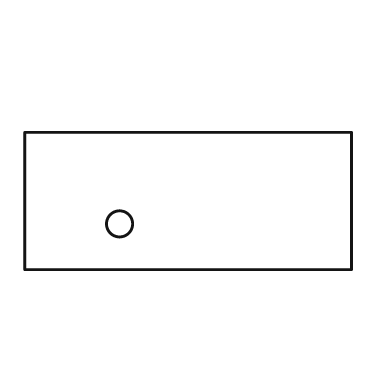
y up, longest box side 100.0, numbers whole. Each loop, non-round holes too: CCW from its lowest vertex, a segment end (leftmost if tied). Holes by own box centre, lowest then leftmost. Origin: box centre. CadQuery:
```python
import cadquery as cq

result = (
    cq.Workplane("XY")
    .moveTo(-50.0, -21.0)
    .lineTo(50.0, -21.0)
    .lineTo(50.0, 21.0)
    .lineTo(-50.0, 21.0)
    .close()
    .moveTo(-21.0, -7.0)
    .circle(4.0)
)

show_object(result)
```